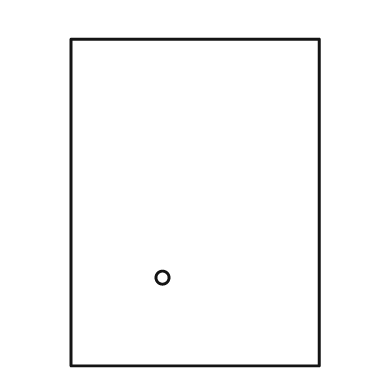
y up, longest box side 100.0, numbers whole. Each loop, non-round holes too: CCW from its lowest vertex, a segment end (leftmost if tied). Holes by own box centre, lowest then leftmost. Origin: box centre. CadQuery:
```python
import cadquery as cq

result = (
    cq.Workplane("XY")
    .moveTo(-38.0, -50.0)
    .lineTo(38.0, -50.0)
    .lineTo(38.0, 50.0)
    .lineTo(-38.0, 50.0)
    .close()
    .moveTo(-10.0, -23.0)
    .circle(2.0)
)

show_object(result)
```